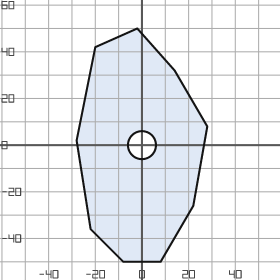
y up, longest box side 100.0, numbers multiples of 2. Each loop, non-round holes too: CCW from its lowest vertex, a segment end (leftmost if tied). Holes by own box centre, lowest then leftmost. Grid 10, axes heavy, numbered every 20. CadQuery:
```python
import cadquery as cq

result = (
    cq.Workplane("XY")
    .moveTo(-8.0, -50.0)
    .lineTo(8.0, -50.0)
    .lineTo(22.0, -26.0)
    .lineTo(28.0, 8.0)
    .lineTo(14.0, 32.0)
    .lineTo(-2.0, 50.0)
    .lineTo(-20.0, 42.0)
    .lineTo(-28.0, 2.0)
    .lineTo(-22.0, -36.0)
    .close()
    .moveTo(0.0, 0.0)
    .circle(6.0)
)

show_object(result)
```